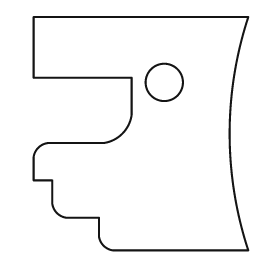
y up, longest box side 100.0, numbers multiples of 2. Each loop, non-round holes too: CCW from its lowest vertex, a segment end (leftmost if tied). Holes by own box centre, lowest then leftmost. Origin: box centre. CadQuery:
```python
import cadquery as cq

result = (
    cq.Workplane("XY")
    .moveTo(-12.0, -50.0)
    .lineTo(46.0, -50.0)
    .threePointArc((38.0, 0.0), (46.0, 50.0))
    .lineTo(-46.0, 50.0)
    .lineTo(-46.0, 24.0)
    .lineTo(-4.0, 24.0)
    .lineTo(-4.0, 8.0)
    .threePointArc((-8.0, 0.0), (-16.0, -4.0))
    .lineTo(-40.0, -4.0)
    .threePointArc((-44.0, -6.0), (-46.0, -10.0))
    .lineTo(-46.0, -20.0)
    .lineTo(-38.0, -20.0)
    .lineTo(-38.0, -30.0)
    .threePointArc((-36.0, -34.0), (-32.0, -36.0))
    .lineTo(-18.0, -36.0)
    .lineTo(-18.0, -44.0)
    .threePointArc((-16.0, -48.0), (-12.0, -50.0))
    .close()
    .moveTo(10.0, 22.0)
    .circle(8.0)
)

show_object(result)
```